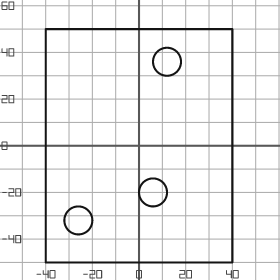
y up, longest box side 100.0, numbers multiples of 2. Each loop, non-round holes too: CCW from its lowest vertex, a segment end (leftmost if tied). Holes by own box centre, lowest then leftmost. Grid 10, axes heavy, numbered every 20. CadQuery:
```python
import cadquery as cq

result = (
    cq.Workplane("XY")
    .moveTo(-40.0, -50.0)
    .lineTo(40.0, -50.0)
    .lineTo(40.0, 50.0)
    .lineTo(-40.0, 50.0)
    .close()
    .moveTo(-26.0, -32.0)
    .circle(6.0)
    .moveTo(6.0, -20.0)
    .circle(6.0)
    .moveTo(12.0, 36.0)
    .circle(6.0)
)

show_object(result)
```